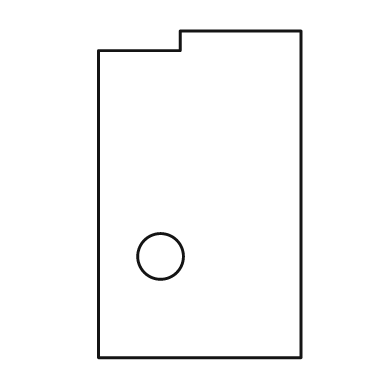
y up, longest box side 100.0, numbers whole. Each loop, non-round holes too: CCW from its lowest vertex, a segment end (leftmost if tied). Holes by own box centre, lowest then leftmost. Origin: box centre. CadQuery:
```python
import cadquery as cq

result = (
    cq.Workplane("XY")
    .moveTo(-31.0, -50.0)
    .lineTo(31.0, -50.0)
    .lineTo(31.0, 50.0)
    .lineTo(-6.0, 50.0)
    .lineTo(-6.0, 44.0)
    .lineTo(-31.0, 44.0)
    .close()
    .moveTo(-12.0, -19.0)
    .circle(7.0)
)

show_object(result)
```